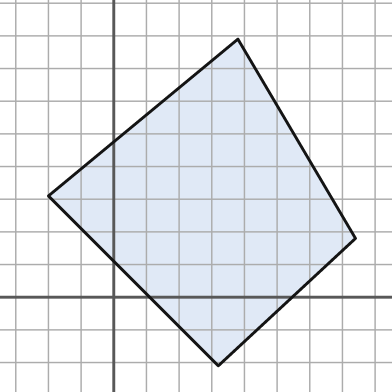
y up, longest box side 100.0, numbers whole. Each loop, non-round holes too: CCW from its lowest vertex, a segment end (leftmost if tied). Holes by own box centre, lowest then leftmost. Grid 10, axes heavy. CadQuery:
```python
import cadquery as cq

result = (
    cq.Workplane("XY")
    .moveTo(32.0, -21.0)
    .lineTo(74.0, 18.0)
    .lineTo(38.0, 79.0)
    .lineTo(-20.0, 31.0)
    .close()
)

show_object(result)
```